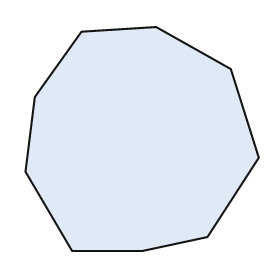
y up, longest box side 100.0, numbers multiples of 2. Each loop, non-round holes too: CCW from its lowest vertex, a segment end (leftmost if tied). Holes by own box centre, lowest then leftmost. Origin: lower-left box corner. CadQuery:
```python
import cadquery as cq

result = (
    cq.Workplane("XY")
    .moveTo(20.0, 0.0)
    .lineTo(50.0, 0.0)
    .lineTo(78.0, 6.0)
    .lineTo(100.0, 40.0)
    .lineTo(88.0, 78.0)
    .lineTo(56.0, 96.0)
    .lineTo(24.0, 94.0)
    .lineTo(4.0, 66.0)
    .lineTo(0.0, 34.0)
    .close()
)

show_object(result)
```